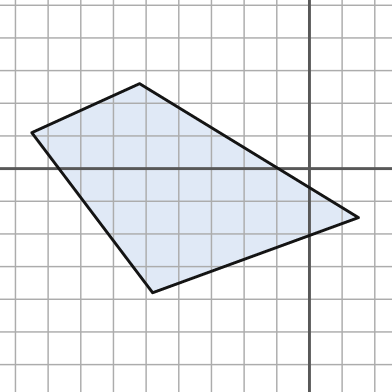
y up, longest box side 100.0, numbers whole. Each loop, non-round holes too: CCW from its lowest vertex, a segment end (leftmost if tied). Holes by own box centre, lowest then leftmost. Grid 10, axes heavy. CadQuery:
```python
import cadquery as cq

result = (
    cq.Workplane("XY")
    .moveTo(-48.0, -38.0)
    .lineTo(15.0, -15.0)
    .lineTo(-52.0, 26.0)
    .lineTo(-85.0, 11.0)
    .close()
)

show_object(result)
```